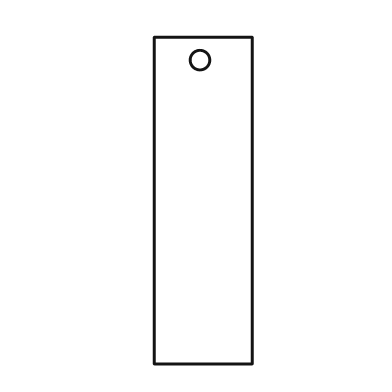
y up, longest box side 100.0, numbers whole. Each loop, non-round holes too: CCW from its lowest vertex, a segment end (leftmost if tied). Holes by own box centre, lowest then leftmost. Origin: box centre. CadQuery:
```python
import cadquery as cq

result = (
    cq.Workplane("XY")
    .moveTo(-15.0, -50.0)
    .lineTo(15.0, -50.0)
    .lineTo(15.0, 50.0)
    .lineTo(-15.0, 50.0)
    .close()
    .moveTo(-1.0, 43.0)
    .circle(3.0)
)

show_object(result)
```